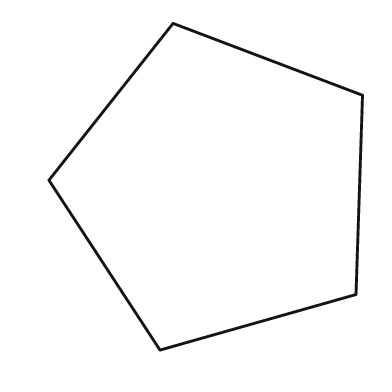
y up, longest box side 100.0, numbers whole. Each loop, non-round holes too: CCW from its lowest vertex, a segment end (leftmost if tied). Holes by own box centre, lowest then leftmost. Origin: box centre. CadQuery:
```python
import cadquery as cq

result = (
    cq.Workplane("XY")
    .moveTo(-14.0, -50.0)
    .lineTo(46.0, -33.0)
    .lineTo(48.0, 28.0)
    .lineTo(-10.0, 50.0)
    .lineTo(-48.0, 2.0)
    .close()
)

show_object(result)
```